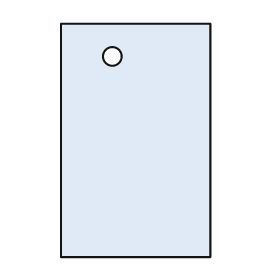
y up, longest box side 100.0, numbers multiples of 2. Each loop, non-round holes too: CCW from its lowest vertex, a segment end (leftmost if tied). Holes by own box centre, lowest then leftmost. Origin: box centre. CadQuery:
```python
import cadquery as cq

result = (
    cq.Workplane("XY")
    .moveTo(-32.0, -50.0)
    .lineTo(32.0, -50.0)
    .lineTo(32.0, 50.0)
    .lineTo(-32.0, 50.0)
    .close()
    .moveTo(-10.0, 36.0)
    .circle(4.0)
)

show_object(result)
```